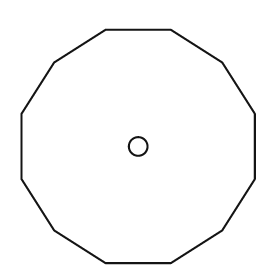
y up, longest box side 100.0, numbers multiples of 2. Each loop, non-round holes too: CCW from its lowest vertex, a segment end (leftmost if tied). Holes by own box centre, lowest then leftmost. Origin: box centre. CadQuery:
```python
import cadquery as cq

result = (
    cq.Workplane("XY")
    .moveTo(-14.0, -50.0)
    .lineTo(14.0, -50.0)
    .lineTo(36.0, -36.0)
    .lineTo(50.0, -14.0)
    .lineTo(50.0, 14.0)
    .lineTo(36.0, 36.0)
    .lineTo(14.0, 50.0)
    .lineTo(-14.0, 50.0)
    .lineTo(-36.0, 36.0)
    .lineTo(-50.0, 14.0)
    .lineTo(-50.0, -14.0)
    .lineTo(-36.0, -36.0)
    .close()
    .moveTo(0.0, 0.0)
    .circle(4.0)
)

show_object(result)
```